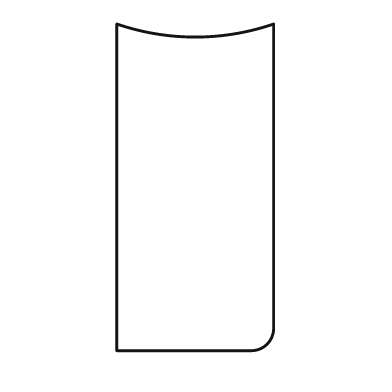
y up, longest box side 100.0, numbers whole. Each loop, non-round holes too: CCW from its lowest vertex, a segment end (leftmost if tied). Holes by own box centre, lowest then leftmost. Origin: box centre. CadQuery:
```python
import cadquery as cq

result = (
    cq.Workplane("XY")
    .moveTo(-24.0, -50.0)
    .lineTo(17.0, -50.0)
    .threePointArc((22.0, -48.0), (24.0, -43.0))
    .lineTo(24.0, 50.0)
    .threePointArc((0.0, 46.0), (-24.0, 50.0))
    .close()
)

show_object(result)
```